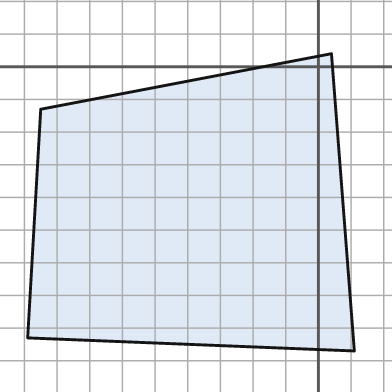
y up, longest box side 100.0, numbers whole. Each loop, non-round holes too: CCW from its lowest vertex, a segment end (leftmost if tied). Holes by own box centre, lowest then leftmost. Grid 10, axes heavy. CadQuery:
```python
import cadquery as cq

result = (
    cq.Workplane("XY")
    .moveTo(11.0, -87.0)
    .lineTo(4.0, 4.0)
    .lineTo(-85.0, -13.0)
    .lineTo(-89.0, -83.0)
    .close()
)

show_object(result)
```